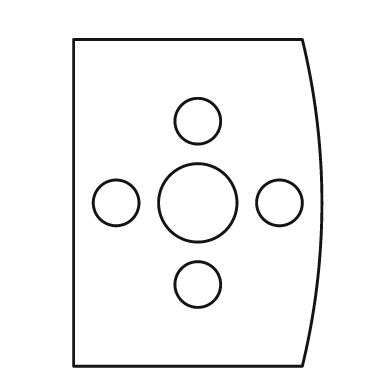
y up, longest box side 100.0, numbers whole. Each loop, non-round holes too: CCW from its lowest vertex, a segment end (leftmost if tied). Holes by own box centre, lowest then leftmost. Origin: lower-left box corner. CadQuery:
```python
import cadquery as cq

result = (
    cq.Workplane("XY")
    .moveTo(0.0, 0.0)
    .lineTo(70.0, 0.0)
    .threePointArc((76.0, 50.0), (70.0, 100.0))
    .lineTo(0.0, 100.0)
    .close()
    .moveTo(38.0, 25.0)
    .circle(7.0)
    .moveTo(13.0, 50.0)
    .circle(7.0)
    .moveTo(38.0, 50.0)
    .circle(12.0)
    .moveTo(63.0, 50.0)
    .circle(7.0)
    .moveTo(38.0, 75.0)
    .circle(7.0)
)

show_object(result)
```